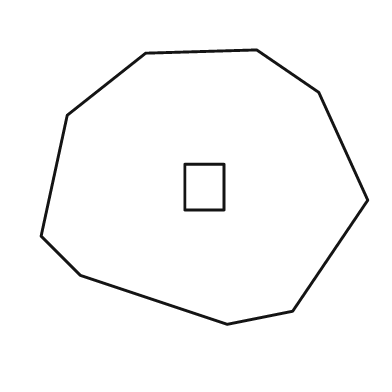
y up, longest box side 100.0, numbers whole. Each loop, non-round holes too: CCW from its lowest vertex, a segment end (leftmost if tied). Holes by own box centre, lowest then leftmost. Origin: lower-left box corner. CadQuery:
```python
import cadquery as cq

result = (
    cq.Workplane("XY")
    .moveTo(57.0, 0.0)
    .lineTo(77.0, 4.0)
    .lineTo(100.0, 38.0)
    .lineTo(85.0, 71.0)
    .lineTo(66.0, 84.0)
    .lineTo(32.0, 83.0)
    .lineTo(8.0, 64.0)
    .lineTo(0.0, 27.0)
    .lineTo(12.0, 15.0)
    .close()
    .moveTo(44.0, 35.0)
    .lineTo(56.0, 35.0)
    .lineTo(56.0, 49.0)
    .lineTo(44.0, 49.0)
    .close()
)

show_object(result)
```